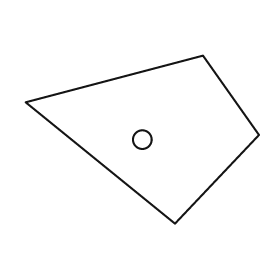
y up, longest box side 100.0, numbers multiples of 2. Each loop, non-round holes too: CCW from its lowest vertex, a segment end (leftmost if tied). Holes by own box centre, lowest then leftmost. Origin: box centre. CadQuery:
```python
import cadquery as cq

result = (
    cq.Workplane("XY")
    .moveTo(14.0, -36.0)
    .lineTo(50.0, 2.0)
    .lineTo(26.0, 36.0)
    .lineTo(-50.0, 16.0)
    .close()
    .moveTo(0.0, 0.0)
    .circle(4.0)
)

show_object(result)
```